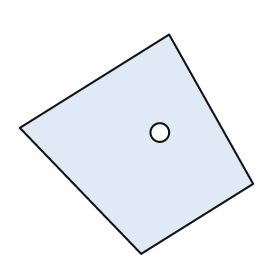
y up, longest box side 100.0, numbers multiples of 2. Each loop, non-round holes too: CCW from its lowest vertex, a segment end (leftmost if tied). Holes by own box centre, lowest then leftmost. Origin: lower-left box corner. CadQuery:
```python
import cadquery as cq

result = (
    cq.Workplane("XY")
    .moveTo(52.0, 0.0)
    .lineTo(100.0, 30.0)
    .lineTo(64.0, 94.0)
    .lineTo(0.0, 54.0)
    .close()
    .moveTo(60.0, 52.0)
    .circle(4.0)
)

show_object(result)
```